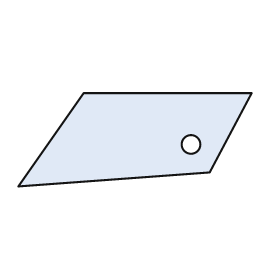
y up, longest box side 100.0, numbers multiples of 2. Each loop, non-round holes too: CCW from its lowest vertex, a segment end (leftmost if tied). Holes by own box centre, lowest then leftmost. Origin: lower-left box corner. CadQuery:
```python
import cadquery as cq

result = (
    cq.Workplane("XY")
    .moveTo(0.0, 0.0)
    .lineTo(82.0, 6.0)
    .lineTo(100.0, 40.0)
    .lineTo(28.0, 40.0)
    .close()
    .moveTo(74.0, 18.0)
    .circle(4.0)
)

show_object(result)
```